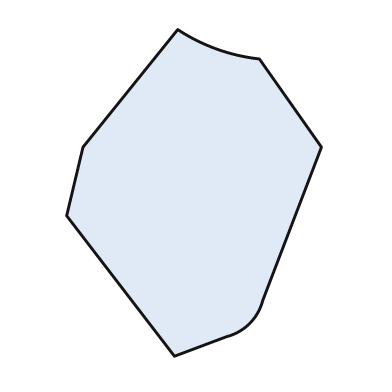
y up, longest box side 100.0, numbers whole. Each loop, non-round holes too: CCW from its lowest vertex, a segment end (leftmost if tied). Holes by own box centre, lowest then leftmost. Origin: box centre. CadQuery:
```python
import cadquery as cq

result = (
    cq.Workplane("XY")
    .moveTo(-6.0, -50.0)
    .lineTo(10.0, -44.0)
    .threePointArc((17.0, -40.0), (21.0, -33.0))
    .lineTo(39.0, 14.0)
    .lineTo(20.0, 41.0)
    .threePointArc((7.0, 44.0), (-5.0, 50.0))
    .lineTo(-34.0, 14.0)
    .lineTo(-39.0, -7.0)
    .close()
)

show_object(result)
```